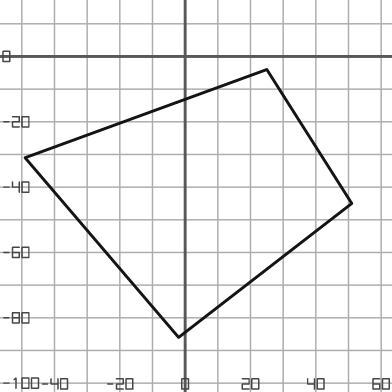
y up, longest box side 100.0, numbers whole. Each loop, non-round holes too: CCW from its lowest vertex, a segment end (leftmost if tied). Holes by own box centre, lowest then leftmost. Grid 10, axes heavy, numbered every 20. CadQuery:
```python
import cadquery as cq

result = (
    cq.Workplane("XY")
    .moveTo(-2.0, -86.0)
    .lineTo(51.0, -45.0)
    .lineTo(25.0, -4.0)
    .lineTo(-49.0, -31.0)
    .close()
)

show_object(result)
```